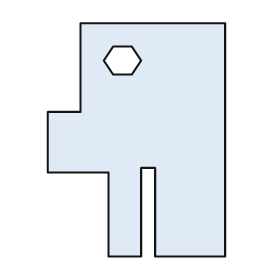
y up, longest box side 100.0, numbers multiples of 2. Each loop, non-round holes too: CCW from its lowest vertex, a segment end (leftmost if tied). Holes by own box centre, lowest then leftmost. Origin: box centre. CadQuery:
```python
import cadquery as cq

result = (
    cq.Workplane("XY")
    .moveTo(-12.0, -50.0)
    .lineTo(2.0, -50.0)
    .lineTo(2.0, -12.0)
    .lineTo(8.0, -12.0)
    .lineTo(8.0, -50.0)
    .lineTo(38.0, -50.0)
    .lineTo(38.0, 50.0)
    .lineTo(-24.0, 50.0)
    .lineTo(-24.0, 12.0)
    .lineTo(-38.0, 12.0)
    .lineTo(-38.0, -14.0)
    .lineTo(-12.0, -14.0)
    .close()
    .moveTo(-10.0, 28.0)
    .lineTo(-2.0, 28.0)
    .lineTo(2.0, 34.0)
    .lineTo(-2.0, 40.0)
    .lineTo(-10.0, 40.0)
    .lineTo(-14.0, 34.0)
    .close()
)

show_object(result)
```